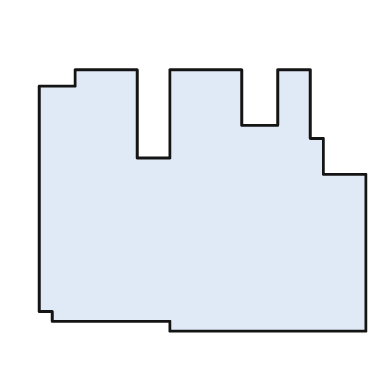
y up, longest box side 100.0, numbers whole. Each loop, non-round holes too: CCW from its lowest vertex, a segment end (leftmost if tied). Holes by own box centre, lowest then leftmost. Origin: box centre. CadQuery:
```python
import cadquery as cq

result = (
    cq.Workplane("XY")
    .moveTo(-10.0, -40.0)
    .lineTo(50.0, -40.0)
    .lineTo(50.0, 8.0)
    .lineTo(37.0, 8.0)
    .lineTo(37.0, 19.0)
    .lineTo(33.0, 19.0)
    .lineTo(33.0, 40.0)
    .lineTo(23.0, 40.0)
    .lineTo(23.0, 23.0)
    .lineTo(12.0, 23.0)
    .lineTo(12.0, 40.0)
    .lineTo(-10.0, 40.0)
    .lineTo(-10.0, 13.0)
    .lineTo(-20.0, 13.0)
    .lineTo(-20.0, 40.0)
    .lineTo(-39.0, 40.0)
    .lineTo(-39.0, 35.0)
    .lineTo(-50.0, 35.0)
    .lineTo(-50.0, -34.0)
    .lineTo(-46.0, -34.0)
    .lineTo(-46.0, -37.0)
    .lineTo(-10.0, -37.0)
    .close()
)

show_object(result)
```